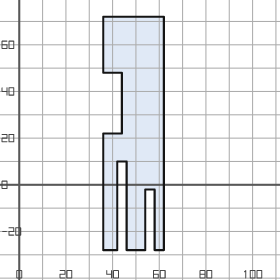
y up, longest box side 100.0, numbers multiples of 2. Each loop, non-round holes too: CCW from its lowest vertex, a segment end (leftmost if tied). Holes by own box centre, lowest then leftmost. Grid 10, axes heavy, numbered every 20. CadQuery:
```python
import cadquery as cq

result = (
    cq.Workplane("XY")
    .moveTo(36.0, -28.0)
    .lineTo(42.0, -28.0)
    .lineTo(42.0, 10.0)
    .lineTo(46.0, 10.0)
    .lineTo(46.0, -28.0)
    .lineTo(54.0, -28.0)
    .lineTo(54.0, -2.0)
    .lineTo(58.0, -2.0)
    .lineTo(58.0, -28.0)
    .lineTo(62.0, -28.0)
    .lineTo(62.0, 72.0)
    .lineTo(36.0, 72.0)
    .lineTo(36.0, 48.0)
    .lineTo(44.0, 48.0)
    .lineTo(44.0, 22.0)
    .lineTo(36.0, 22.0)
    .close()
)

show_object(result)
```